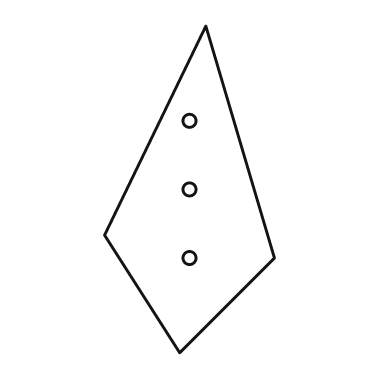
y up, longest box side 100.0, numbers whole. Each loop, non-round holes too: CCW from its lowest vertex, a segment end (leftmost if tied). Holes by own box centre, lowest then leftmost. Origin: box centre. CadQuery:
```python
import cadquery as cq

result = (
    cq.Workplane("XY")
    .moveTo(-3.0, -50.0)
    .lineTo(26.0, -21.0)
    .lineTo(5.0, 50.0)
    .lineTo(-26.0, -14.0)
    .close()
    .moveTo(0.0, -21.0)
    .circle(2.0)
    .moveTo(0.0, 0.0)
    .circle(2.0)
    .moveTo(0.0, 21.0)
    .circle(2.0)
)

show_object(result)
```